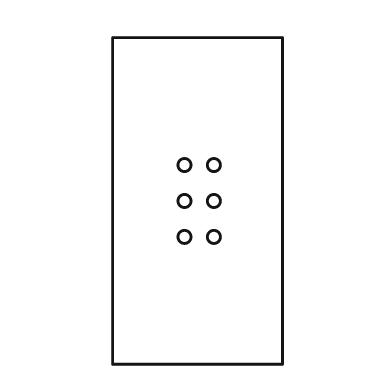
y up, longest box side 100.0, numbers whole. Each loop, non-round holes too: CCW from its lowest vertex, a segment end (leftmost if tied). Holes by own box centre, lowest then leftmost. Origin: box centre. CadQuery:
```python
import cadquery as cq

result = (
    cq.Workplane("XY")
    .moveTo(-26.0, -50.0)
    .lineTo(26.0, -50.0)
    .lineTo(26.0, 50.0)
    .lineTo(-26.0, 50.0)
    .close()
    .moveTo(-4.0, -11.0)
    .circle(2.0)
    .moveTo(5.0, -11.0)
    .circle(2.0)
    .moveTo(-4.0, 0.0)
    .circle(2.0)
    .moveTo(5.0, 0.0)
    .circle(2.0)
    .moveTo(-4.0, 11.0)
    .circle(2.0)
    .moveTo(5.0, 11.0)
    .circle(2.0)
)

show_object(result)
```